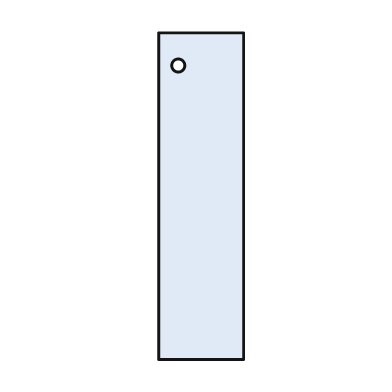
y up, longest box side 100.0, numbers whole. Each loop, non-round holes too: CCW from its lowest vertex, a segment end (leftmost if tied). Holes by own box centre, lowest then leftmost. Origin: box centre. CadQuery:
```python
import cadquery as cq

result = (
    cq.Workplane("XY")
    .moveTo(-13.0, -50.0)
    .lineTo(13.0, -50.0)
    .lineTo(13.0, 50.0)
    .lineTo(-13.0, 50.0)
    .close()
    .moveTo(-7.0, 40.0)
    .circle(2.0)
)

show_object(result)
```